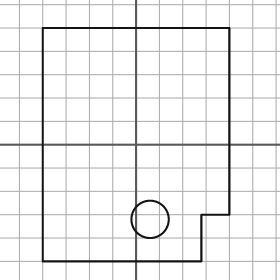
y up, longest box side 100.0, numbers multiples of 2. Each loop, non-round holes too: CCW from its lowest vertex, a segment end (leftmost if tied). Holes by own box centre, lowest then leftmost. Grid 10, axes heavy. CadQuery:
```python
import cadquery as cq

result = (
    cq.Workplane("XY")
    .moveTo(-40.0, -50.0)
    .lineTo(28.0, -50.0)
    .lineTo(28.0, -30.0)
    .lineTo(40.0, -30.0)
    .lineTo(40.0, 50.0)
    .lineTo(-40.0, 50.0)
    .close()
    .moveTo(6.0, -32.0)
    .circle(8.0)
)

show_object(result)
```